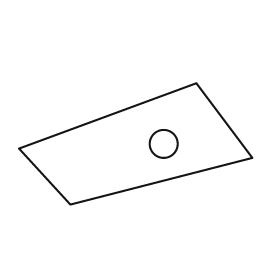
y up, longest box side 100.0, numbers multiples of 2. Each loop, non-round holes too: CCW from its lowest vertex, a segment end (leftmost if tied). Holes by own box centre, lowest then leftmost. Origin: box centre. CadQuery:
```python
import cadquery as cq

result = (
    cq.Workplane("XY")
    .moveTo(-28.0, -26.0)
    .lineTo(50.0, -6.0)
    .lineTo(26.0, 26.0)
    .lineTo(-50.0, -2.0)
    .close()
    .moveTo(12.0, 0.0)
    .circle(6.0)
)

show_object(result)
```